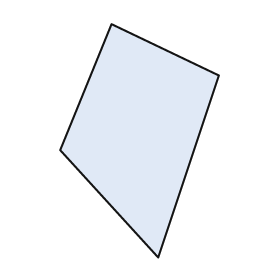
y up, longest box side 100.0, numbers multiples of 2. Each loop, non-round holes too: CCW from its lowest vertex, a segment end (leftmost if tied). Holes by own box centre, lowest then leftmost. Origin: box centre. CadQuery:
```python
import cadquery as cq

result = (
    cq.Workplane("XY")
    .moveTo(8.0, -50.0)
    .lineTo(34.0, 28.0)
    .lineTo(-12.0, 50.0)
    .lineTo(-34.0, -4.0)
    .close()
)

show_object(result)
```